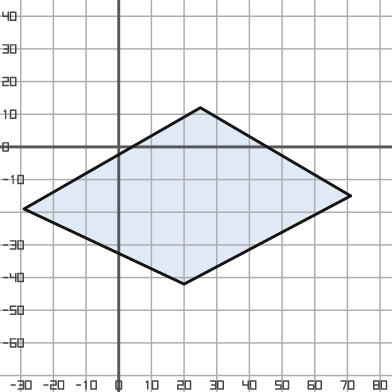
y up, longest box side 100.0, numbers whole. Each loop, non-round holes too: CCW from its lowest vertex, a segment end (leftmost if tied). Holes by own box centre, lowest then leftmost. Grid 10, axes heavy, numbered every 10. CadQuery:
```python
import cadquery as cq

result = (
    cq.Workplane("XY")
    .moveTo(20.0, -42.0)
    .lineTo(71.0, -15.0)
    .lineTo(25.0, 12.0)
    .lineTo(-29.0, -19.0)
    .close()
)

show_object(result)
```